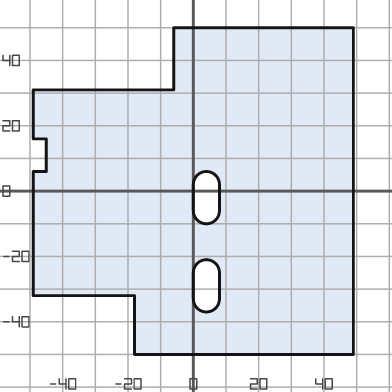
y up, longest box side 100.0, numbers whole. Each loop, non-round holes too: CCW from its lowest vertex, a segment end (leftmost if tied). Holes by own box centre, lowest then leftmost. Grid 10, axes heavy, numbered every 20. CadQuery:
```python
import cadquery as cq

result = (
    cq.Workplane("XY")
    .moveTo(-18.0, -50.0)
    .lineTo(49.0, -50.0)
    .lineTo(49.0, 50.0)
    .lineTo(-6.0, 50.0)
    .lineTo(-6.0, 31.0)
    .lineTo(-49.0, 31.0)
    .lineTo(-49.0, 16.0)
    .lineTo(-45.0, 16.0)
    .lineTo(-45.0, 6.0)
    .lineTo(-49.0, 6.0)
    .lineTo(-49.0, -32.0)
    .lineTo(-18.0, -32.0)
    .close()
    .moveTo(0.0, -33.0)
    .threePointArc((4.0, -37.0), (8.0, -33.0))
    .lineTo(8.0, -25.0)
    .threePointArc((4.0, -21.0), (0.0, -25.0))
    .close()
    .moveTo(0.0, -6.0)
    .threePointArc((4.0, -10.0), (8.0, -6.0))
    .lineTo(8.0, 2.0)
    .threePointArc((4.0, 6.0), (0.0, 2.0))
    .close()
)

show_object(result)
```